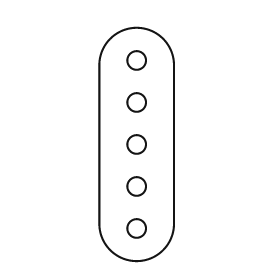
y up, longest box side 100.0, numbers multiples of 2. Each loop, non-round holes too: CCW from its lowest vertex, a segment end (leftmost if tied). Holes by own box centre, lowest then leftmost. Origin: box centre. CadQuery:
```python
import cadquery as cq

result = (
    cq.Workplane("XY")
    .moveTo(-16.0, -34.0)
    .threePointArc((0.0, -50.0), (16.0, -34.0))
    .lineTo(16.0, 34.0)
    .threePointArc((0.0, 50.0), (-16.0, 34.0))
    .close()
    .moveTo(0.0, -36.0)
    .circle(4.0)
    .moveTo(0.0, -18.0)
    .circle(4.0)
    .moveTo(0.0, 0.0)
    .circle(4.0)
    .moveTo(0.0, 18.0)
    .circle(4.0)
    .moveTo(0.0, 36.0)
    .circle(4.0)
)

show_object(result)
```